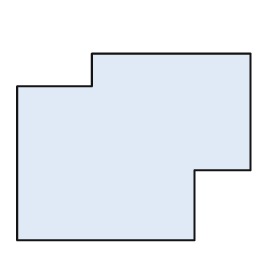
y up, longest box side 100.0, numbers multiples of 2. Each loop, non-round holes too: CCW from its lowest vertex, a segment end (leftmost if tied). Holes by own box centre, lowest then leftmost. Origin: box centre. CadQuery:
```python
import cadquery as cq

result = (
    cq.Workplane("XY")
    .moveTo(-50.0, -40.0)
    .lineTo(26.0, -40.0)
    .lineTo(26.0, -10.0)
    .lineTo(50.0, -10.0)
    .lineTo(50.0, 40.0)
    .lineTo(-18.0, 40.0)
    .lineTo(-18.0, 26.0)
    .lineTo(-50.0, 26.0)
    .close()
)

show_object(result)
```